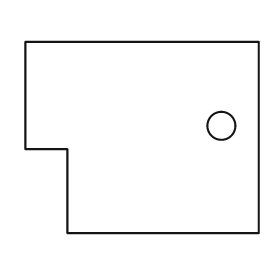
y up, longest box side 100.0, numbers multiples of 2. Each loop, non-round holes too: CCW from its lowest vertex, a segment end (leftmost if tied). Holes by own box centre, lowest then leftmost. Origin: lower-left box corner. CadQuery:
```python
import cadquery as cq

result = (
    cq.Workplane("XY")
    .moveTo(18.0, 0.0)
    .lineTo(100.0, 0.0)
    .lineTo(100.0, 82.0)
    .lineTo(0.0, 82.0)
    .lineTo(0.0, 36.0)
    .lineTo(18.0, 36.0)
    .close()
    .moveTo(84.0, 46.0)
    .circle(6.0)
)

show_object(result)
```